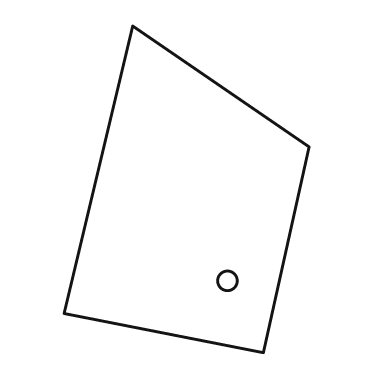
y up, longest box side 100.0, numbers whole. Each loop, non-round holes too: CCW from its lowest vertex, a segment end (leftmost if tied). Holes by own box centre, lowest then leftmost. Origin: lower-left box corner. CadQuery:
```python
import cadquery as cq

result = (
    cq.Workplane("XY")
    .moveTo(61.0, 0.0)
    .lineTo(75.0, 63.0)
    .lineTo(21.0, 100.0)
    .lineTo(0.0, 12.0)
    .close()
    .moveTo(50.0, 22.0)
    .circle(3.0)
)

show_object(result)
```